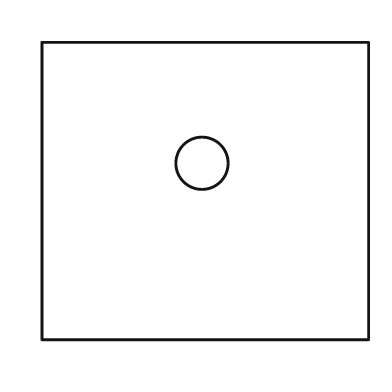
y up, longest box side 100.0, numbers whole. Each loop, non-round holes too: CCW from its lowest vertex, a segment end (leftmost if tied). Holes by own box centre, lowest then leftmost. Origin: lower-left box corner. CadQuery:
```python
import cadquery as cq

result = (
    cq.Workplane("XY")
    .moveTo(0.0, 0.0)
    .lineTo(100.0, 0.0)
    .lineTo(100.0, 91.0)
    .lineTo(0.0, 91.0)
    .close()
    .moveTo(49.0, 54.0)
    .circle(8.0)
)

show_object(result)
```